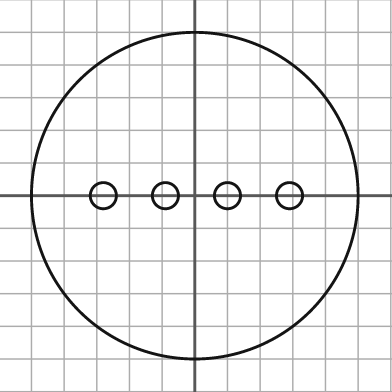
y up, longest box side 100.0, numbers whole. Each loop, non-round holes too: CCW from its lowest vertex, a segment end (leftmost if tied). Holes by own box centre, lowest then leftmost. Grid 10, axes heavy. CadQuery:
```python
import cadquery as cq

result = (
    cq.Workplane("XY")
    .moveTo(0.0, 0.0)
    .circle(50.0)
    .moveTo(-28.0, 0.0)
    .circle(4.0)
    .moveTo(-9.0, 0.0)
    .circle(4.0)
    .moveTo(10.0, 0.0)
    .circle(4.0)
    .moveTo(29.0, 0.0)
    .circle(4.0)
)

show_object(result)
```